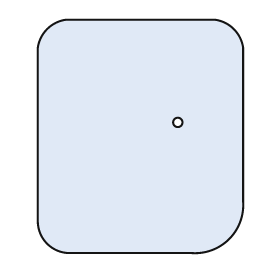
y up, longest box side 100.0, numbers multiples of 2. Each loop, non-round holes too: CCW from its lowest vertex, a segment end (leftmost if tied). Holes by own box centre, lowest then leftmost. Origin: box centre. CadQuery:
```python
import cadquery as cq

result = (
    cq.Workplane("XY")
    .moveTo(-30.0, -50.0)
    .lineTo(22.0, -50.0)
    .threePointArc((38.0, -44.0), (44.0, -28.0))
    .lineTo(44.0, 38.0)
    .threePointArc((40.0, 46.0), (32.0, 50.0))
    .lineTo(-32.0, 50.0)
    .threePointArc((-40.0, 46.0), (-44.0, 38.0))
    .lineTo(-44.0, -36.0)
    .threePointArc((-40.0, -46.0), (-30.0, -50.0))
    .close()
    .moveTo(16.0, 6.0)
    .circle(2.0)
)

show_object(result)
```